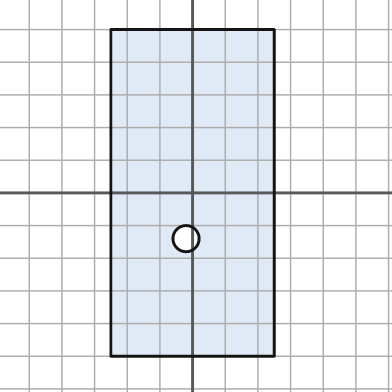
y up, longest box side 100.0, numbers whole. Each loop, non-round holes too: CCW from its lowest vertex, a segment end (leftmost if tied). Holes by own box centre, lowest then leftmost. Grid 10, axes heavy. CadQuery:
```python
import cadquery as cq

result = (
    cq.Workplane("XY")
    .moveTo(-25.0, -50.0)
    .lineTo(25.0, -50.0)
    .lineTo(25.0, 50.0)
    .lineTo(-25.0, 50.0)
    .close()
    .moveTo(-2.0, -14.0)
    .circle(4.0)
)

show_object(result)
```